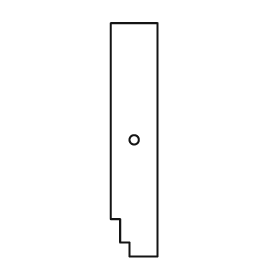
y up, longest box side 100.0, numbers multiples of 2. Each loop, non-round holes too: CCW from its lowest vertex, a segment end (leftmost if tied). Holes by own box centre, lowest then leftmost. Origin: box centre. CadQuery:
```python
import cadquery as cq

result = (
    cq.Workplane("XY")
    .moveTo(-2.0, -50.0)
    .lineTo(10.0, -50.0)
    .lineTo(10.0, 50.0)
    .lineTo(-10.0, 50.0)
    .lineTo(-10.0, -34.0)
    .lineTo(-6.0, -34.0)
    .lineTo(-6.0, -44.0)
    .lineTo(-2.0, -44.0)
    .close()
    .moveTo(0.0, 0.0)
    .circle(2.0)
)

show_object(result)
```